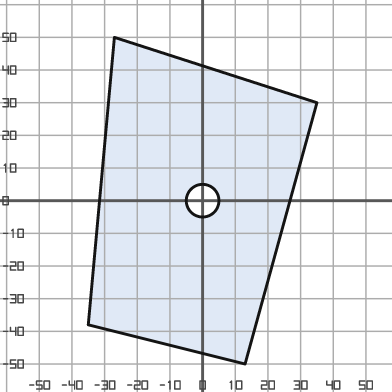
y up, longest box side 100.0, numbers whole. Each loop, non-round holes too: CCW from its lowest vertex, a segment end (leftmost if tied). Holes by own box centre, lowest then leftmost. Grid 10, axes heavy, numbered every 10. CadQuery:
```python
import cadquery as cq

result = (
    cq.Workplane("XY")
    .moveTo(13.0, -50.0)
    .lineTo(35.0, 30.0)
    .lineTo(-27.0, 50.0)
    .lineTo(-35.0, -38.0)
    .close()
    .moveTo(0.0, 0.0)
    .circle(5.0)
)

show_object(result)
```